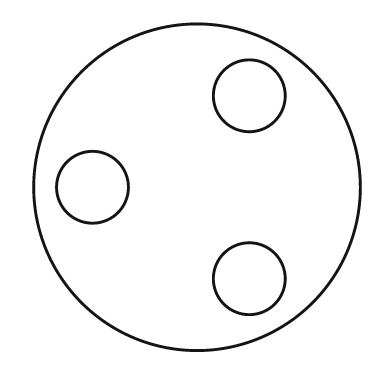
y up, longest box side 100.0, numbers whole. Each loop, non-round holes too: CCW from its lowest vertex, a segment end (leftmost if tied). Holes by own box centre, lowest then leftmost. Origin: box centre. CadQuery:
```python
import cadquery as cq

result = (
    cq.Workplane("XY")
    .moveTo(0.0, 0.0)
    .circle(50.0)
    .moveTo(16.0, -28.0)
    .circle(11.0)
    .moveTo(-32.0, 0.0)
    .circle(11.0)
    .moveTo(16.0, 28.0)
    .circle(11.0)
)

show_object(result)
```